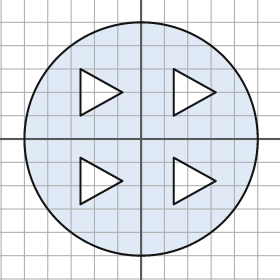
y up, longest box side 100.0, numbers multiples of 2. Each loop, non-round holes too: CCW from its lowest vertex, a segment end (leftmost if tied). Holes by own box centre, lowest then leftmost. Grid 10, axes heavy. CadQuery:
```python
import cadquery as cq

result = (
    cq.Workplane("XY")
    .moveTo(0.0, 0.0)
    .circle(50.0)
    .moveTo(-26.0, -28.0)
    .lineTo(-8.0, -18.0)
    .lineTo(-26.0, -8.0)
    .close()
    .moveTo(14.0, -28.0)
    .lineTo(32.0, -18.0)
    .lineTo(14.0, -8.0)
    .close()
    .moveTo(-26.0, 10.0)
    .lineTo(-8.0, 20.0)
    .lineTo(-26.0, 30.0)
    .close()
    .moveTo(14.0, 10.0)
    .lineTo(32.0, 20.0)
    .lineTo(14.0, 30.0)
    .close()
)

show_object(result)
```